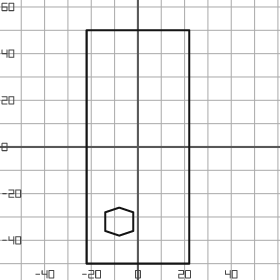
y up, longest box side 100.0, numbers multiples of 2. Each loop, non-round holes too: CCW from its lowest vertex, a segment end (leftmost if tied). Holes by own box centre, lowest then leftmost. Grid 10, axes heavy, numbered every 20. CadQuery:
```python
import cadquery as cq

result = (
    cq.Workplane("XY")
    .moveTo(-22.0, -50.0)
    .lineTo(22.0, -50.0)
    .lineTo(22.0, 50.0)
    .lineTo(-22.0, 50.0)
    .close()
    .moveTo(-8.0, -38.0)
    .lineTo(-2.0, -36.0)
    .lineTo(-2.0, -28.0)
    .lineTo(-8.0, -26.0)
    .lineTo(-14.0, -28.0)
    .lineTo(-14.0, -36.0)
    .close()
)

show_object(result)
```